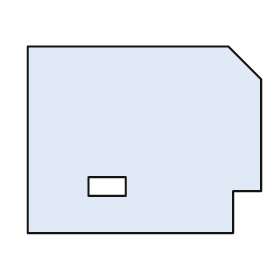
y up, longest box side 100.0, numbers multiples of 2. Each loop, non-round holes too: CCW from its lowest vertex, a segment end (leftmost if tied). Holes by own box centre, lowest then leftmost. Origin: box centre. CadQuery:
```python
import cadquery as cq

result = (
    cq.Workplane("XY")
    .moveTo(-50.0, -40.0)
    .lineTo(38.0, -40.0)
    .lineTo(38.0, -22.0)
    .lineTo(50.0, -22.0)
    .lineTo(50.0, 26.0)
    .lineTo(36.0, 40.0)
    .lineTo(-50.0, 40.0)
    .close()
    .moveTo(-24.0, -24.0)
    .lineTo(-8.0, -24.0)
    .lineTo(-8.0, -16.0)
    .lineTo(-24.0, -16.0)
    .close()
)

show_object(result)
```